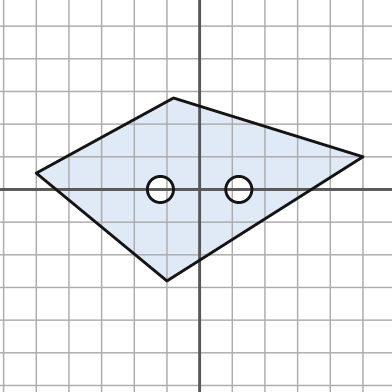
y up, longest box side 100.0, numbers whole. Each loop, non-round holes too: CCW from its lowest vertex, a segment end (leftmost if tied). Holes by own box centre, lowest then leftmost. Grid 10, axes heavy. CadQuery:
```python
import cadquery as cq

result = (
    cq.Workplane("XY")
    .moveTo(-10.0, -28.0)
    .lineTo(50.0, 10.0)
    .lineTo(-8.0, 28.0)
    .lineTo(-50.0, 5.0)
    .close()
    .moveTo(-12.0, 0.0)
    .circle(4.0)
    .moveTo(12.0, 0.0)
    .circle(4.0)
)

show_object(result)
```